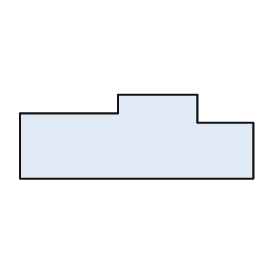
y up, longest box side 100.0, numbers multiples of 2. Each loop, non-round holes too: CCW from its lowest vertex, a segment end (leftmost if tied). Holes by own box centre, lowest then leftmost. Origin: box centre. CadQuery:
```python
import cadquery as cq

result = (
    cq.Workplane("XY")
    .moveTo(-50.0, -18.0)
    .lineTo(50.0, -18.0)
    .lineTo(50.0, 6.0)
    .lineTo(26.0, 6.0)
    .lineTo(26.0, 18.0)
    .lineTo(-8.0, 18.0)
    .lineTo(-8.0, 10.0)
    .lineTo(-50.0, 10.0)
    .close()
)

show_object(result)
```